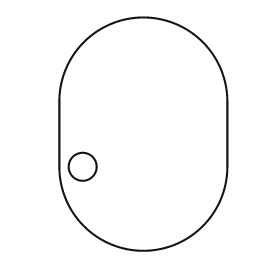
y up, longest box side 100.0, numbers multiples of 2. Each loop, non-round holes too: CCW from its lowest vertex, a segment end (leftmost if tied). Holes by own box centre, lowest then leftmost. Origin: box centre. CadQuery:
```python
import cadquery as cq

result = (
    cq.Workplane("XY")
    .moveTo(-36.0, -14.0)
    .threePointArc((0.0, -50.0), (36.0, -14.0))
    .lineTo(36.0, 14.0)
    .threePointArc((0.0, 50.0), (-36.0, 14.0))
    .close()
    .moveTo(-26.0, -14.0)
    .circle(6.0)
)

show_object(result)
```